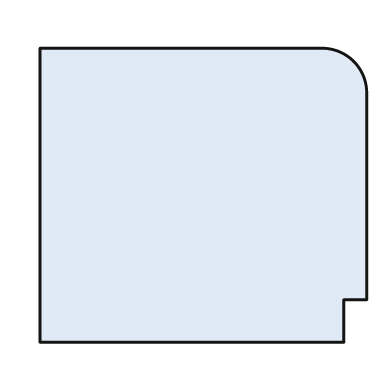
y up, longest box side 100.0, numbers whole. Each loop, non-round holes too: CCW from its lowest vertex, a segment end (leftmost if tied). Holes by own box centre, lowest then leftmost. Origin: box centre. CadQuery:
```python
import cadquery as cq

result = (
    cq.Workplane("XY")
    .moveTo(-50.0, -45.0)
    .lineTo(43.0, -45.0)
    .lineTo(43.0, -32.0)
    .lineTo(50.0, -32.0)
    .lineTo(50.0, 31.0)
    .threePointArc((46.0, 41.0), (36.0, 45.0))
    .lineTo(-50.0, 45.0)
    .close()
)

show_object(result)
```